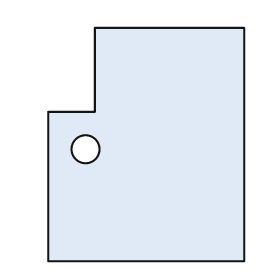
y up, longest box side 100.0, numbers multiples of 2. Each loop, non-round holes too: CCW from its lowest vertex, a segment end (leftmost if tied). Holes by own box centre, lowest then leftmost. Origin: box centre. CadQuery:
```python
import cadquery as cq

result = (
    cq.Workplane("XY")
    .moveTo(-42.0, -50.0)
    .lineTo(42.0, -50.0)
    .lineTo(42.0, 50.0)
    .lineTo(-22.0, 50.0)
    .lineTo(-22.0, 14.0)
    .lineTo(-42.0, 14.0)
    .close()
    .moveTo(-26.0, -2.0)
    .circle(6.0)
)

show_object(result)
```